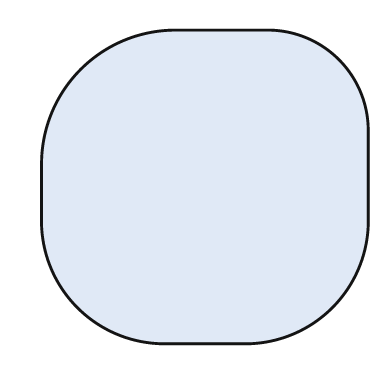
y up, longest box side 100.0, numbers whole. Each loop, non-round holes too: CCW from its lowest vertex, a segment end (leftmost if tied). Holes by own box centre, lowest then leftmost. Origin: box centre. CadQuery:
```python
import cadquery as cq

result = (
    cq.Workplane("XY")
    .moveTo(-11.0, -48.0)
    .lineTo(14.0, -48.0)
    .threePointArc((39.0, -37.0), (50.0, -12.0))
    .lineTo(50.0, 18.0)
    .threePointArc((41.0, 39.0), (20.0, 48.0))
    .lineTo(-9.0, 48.0)
    .threePointArc((-38.0, 36.0), (-50.0, 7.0))
    .lineTo(-50.0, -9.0)
    .threePointArc((-39.0, -37.0), (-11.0, -48.0))
    .close()
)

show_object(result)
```